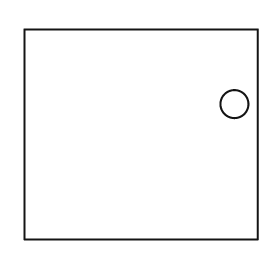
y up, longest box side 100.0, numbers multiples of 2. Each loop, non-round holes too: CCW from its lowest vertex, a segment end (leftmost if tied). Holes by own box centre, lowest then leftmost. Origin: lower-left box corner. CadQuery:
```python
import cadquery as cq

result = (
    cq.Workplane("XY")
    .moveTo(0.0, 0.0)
    .lineTo(100.0, 0.0)
    .lineTo(100.0, 90.0)
    .lineTo(0.0, 90.0)
    .close()
    .moveTo(90.0, 58.0)
    .circle(6.0)
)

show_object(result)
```